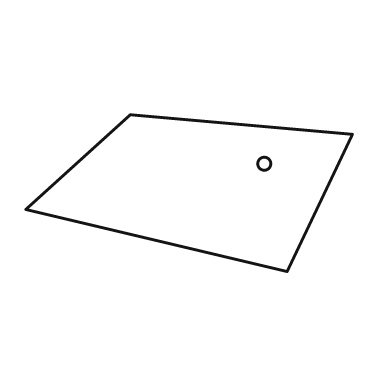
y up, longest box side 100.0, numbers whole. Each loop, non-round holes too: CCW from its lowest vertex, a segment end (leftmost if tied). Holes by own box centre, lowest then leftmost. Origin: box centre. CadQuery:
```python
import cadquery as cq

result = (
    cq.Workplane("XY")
    .moveTo(30.0, -24.0)
    .lineTo(50.0, 18.0)
    .lineTo(-18.0, 24.0)
    .lineTo(-50.0, -5.0)
    .close()
    .moveTo(23.0, 9.0)
    .circle(2.0)
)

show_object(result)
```